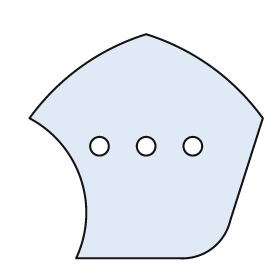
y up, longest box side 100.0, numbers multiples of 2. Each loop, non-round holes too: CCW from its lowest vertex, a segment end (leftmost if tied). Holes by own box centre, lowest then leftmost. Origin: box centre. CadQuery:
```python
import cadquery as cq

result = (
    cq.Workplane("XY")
    .moveTo(-30.0, -48.0)
    .lineTo(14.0, -48.0)
    .threePointArc((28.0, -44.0), (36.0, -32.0))
    .lineTo(50.0, 12.0)
    .threePointArc((28.0, 34.0), (0.0, 48.0))
    .threePointArc((-28.0, 34.0), (-50.0, 12.0))
    .threePointArc((-28.0, -14.0), (-30.0, -48.0))
    .close()
    .moveTo(-20.0, 0.0)
    .circle(4.0)
    .moveTo(0.0, 0.0)
    .circle(4.0)
    .moveTo(20.0, 0.0)
    .circle(4.0)
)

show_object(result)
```